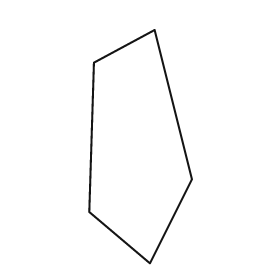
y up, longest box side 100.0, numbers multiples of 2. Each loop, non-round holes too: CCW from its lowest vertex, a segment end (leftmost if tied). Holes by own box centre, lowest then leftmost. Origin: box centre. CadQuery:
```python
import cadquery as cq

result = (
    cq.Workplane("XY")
    .moveTo(4.0, -50.0)
    .lineTo(22.0, -14.0)
    .lineTo(6.0, 50.0)
    .lineTo(-20.0, 36.0)
    .lineTo(-22.0, -28.0)
    .close()
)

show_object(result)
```